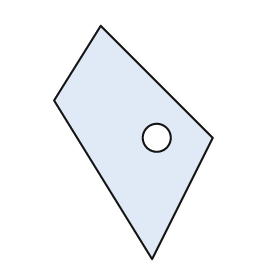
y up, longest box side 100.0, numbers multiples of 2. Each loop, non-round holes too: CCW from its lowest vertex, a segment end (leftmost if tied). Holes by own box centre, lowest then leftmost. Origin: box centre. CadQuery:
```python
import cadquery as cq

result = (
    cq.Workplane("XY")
    .moveTo(8.0, -50.0)
    .lineTo(34.0, 2.0)
    .lineTo(-14.0, 50.0)
    .lineTo(-34.0, 18.0)
    .close()
    .moveTo(10.0, 2.0)
    .circle(6.0)
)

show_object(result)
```